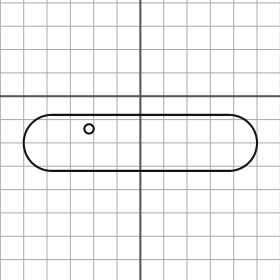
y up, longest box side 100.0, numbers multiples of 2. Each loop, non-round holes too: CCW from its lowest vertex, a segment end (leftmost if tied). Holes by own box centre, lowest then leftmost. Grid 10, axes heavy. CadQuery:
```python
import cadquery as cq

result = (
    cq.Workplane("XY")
    .moveTo(-38.0, -32.0)
    .lineTo(38.0, -32.0)
    .threePointArc((50.0, -20.0), (38.0, -8.0))
    .lineTo(-38.0, -8.0)
    .threePointArc((-50.0, -20.0), (-38.0, -32.0))
    .close()
    .moveTo(-22.0, -14.0)
    .circle(2.0)
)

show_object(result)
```